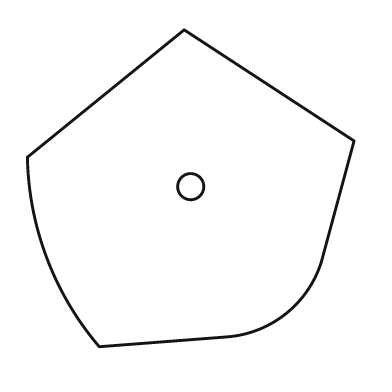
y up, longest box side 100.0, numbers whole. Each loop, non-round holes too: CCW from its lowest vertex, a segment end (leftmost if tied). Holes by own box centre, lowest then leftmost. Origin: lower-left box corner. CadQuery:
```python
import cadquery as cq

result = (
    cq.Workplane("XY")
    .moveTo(22.0, 0.0)
    .lineTo(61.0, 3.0)
    .threePointArc((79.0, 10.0), (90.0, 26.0))
    .lineTo(100.0, 63.0)
    .lineTo(48.0, 97.0)
    .lineTo(0.0, 58.0)
    .threePointArc((6.0, 27.0), (22.0, 0.0))
    .close()
    .moveTo(50.0, 49.0)
    .circle(4.0)
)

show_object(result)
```